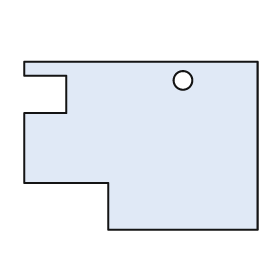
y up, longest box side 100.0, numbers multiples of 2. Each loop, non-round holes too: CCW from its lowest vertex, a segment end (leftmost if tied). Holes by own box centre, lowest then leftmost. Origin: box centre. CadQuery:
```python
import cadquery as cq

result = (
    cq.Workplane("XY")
    .moveTo(-14.0, -36.0)
    .lineTo(50.0, -36.0)
    .lineTo(50.0, 36.0)
    .lineTo(-50.0, 36.0)
    .lineTo(-50.0, 30.0)
    .lineTo(-32.0, 30.0)
    .lineTo(-32.0, 14.0)
    .lineTo(-50.0, 14.0)
    .lineTo(-50.0, -16.0)
    .lineTo(-14.0, -16.0)
    .close()
    .moveTo(18.0, 28.0)
    .circle(4.0)
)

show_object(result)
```